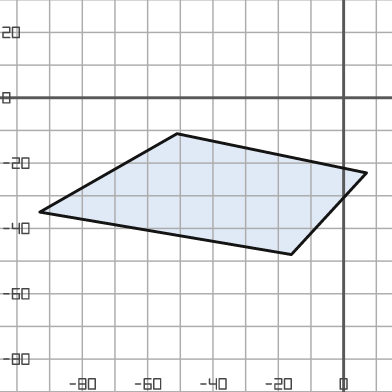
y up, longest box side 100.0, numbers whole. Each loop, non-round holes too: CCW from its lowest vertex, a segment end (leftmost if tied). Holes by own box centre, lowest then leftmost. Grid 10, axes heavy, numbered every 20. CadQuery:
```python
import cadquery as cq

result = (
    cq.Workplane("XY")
    .moveTo(-16.0, -48.0)
    .lineTo(7.0, -23.0)
    .lineTo(-51.0, -11.0)
    .lineTo(-93.0, -35.0)
    .close()
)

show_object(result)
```